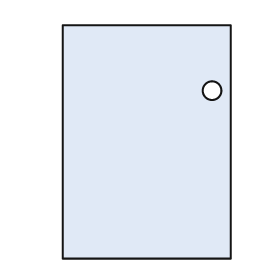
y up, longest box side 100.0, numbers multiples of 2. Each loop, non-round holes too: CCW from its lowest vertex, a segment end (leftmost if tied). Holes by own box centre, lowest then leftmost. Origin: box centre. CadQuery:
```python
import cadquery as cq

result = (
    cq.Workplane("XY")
    .moveTo(-36.0, -50.0)
    .lineTo(36.0, -50.0)
    .lineTo(36.0, 50.0)
    .lineTo(-36.0, 50.0)
    .close()
    .moveTo(28.0, 22.0)
    .circle(4.0)
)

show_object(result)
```